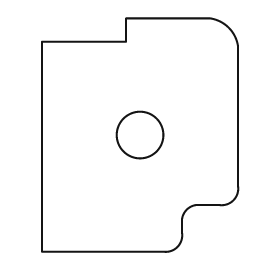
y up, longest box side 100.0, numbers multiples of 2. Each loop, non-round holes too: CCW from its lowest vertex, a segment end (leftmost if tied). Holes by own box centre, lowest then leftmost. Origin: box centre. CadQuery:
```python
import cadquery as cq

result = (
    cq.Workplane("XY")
    .moveTo(-42.0, -50.0)
    .lineTo(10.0, -50.0)
    .threePointArc((16.0, -48.0), (18.0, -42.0))
    .lineTo(18.0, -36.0)
    .threePointArc((20.0, -32.0), (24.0, -30.0))
    .lineTo(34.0, -30.0)
    .threePointArc((40.0, -28.0), (42.0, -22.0))
    .lineTo(42.0, 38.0)
    .threePointArc((38.0, 46.0), (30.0, 50.0))
    .lineTo(-6.0, 50.0)
    .lineTo(-6.0, 40.0)
    .lineTo(-42.0, 40.0)
    .close()
    .moveTo(0.0, 0.0)
    .circle(10.0)
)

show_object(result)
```